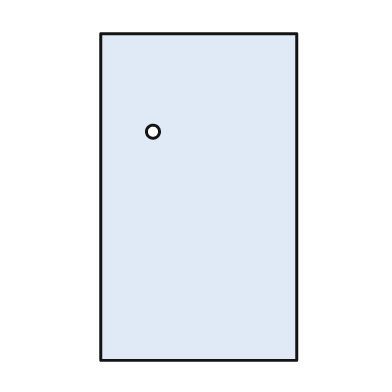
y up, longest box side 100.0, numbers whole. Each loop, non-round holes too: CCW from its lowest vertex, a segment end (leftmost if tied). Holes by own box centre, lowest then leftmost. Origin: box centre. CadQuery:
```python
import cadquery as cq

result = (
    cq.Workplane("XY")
    .moveTo(-30.0, -50.0)
    .lineTo(30.0, -50.0)
    .lineTo(30.0, 50.0)
    .lineTo(-30.0, 50.0)
    .close()
    .moveTo(-14.0, 20.0)
    .circle(2.0)
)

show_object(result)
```